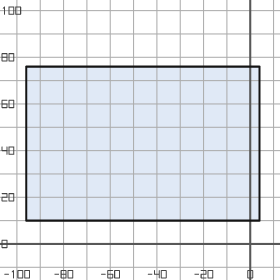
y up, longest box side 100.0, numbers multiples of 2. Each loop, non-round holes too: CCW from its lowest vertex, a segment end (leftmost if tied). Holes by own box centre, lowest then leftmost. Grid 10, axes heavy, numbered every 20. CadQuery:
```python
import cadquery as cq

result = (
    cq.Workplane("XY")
    .moveTo(-96.0, 10.0)
    .lineTo(4.0, 10.0)
    .lineTo(4.0, 76.0)
    .lineTo(-96.0, 76.0)
    .close()
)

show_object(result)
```